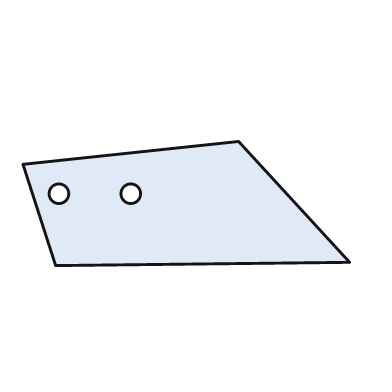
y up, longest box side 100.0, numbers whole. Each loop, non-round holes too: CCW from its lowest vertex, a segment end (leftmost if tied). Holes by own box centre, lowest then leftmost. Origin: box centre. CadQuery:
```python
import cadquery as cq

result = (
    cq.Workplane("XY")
    .moveTo(-40.0, -19.0)
    .lineTo(50.0, -18.0)
    .lineTo(16.0, 19.0)
    .lineTo(-50.0, 12.0)
    .close()
    .moveTo(-39.0, 3.0)
    .circle(3.0)
    .moveTo(-17.0, 3.0)
    .circle(3.0)
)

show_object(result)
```